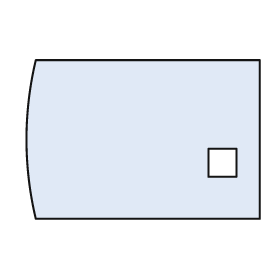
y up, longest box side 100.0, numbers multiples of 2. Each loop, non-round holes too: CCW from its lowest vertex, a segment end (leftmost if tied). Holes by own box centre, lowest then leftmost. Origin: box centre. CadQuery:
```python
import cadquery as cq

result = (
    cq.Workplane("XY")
    .moveTo(-46.0, -34.0)
    .lineTo(50.0, -34.0)
    .lineTo(50.0, 34.0)
    .lineTo(-46.0, 34.0)
    .threePointArc((-50.0, 0.0), (-46.0, -34.0))
    .close()
    .moveTo(28.0, -16.0)
    .lineTo(40.0, -16.0)
    .lineTo(40.0, -4.0)
    .lineTo(28.0, -4.0)
    .close()
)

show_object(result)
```